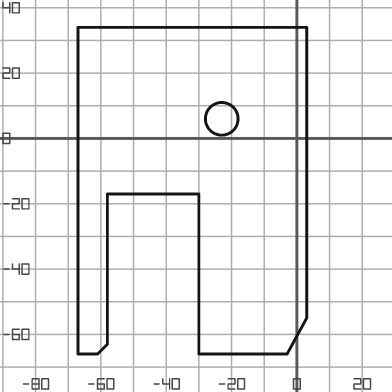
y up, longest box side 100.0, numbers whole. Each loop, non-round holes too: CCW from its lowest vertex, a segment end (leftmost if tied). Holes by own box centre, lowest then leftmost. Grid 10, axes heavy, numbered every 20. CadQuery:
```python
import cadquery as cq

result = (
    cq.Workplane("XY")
    .moveTo(-67.0, -66.0)
    .lineTo(-61.0, -66.0)
    .lineTo(-58.0, -63.0)
    .lineTo(-58.0, -17.0)
    .lineTo(-30.0, -17.0)
    .lineTo(-30.0, -66.0)
    .lineTo(-3.0, -66.0)
    .lineTo(3.0, -55.0)
    .lineTo(3.0, 34.0)
    .lineTo(-67.0, 34.0)
    .close()
    .moveTo(-23.0, 6.0)
    .circle(5.0)
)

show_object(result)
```